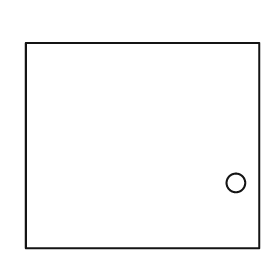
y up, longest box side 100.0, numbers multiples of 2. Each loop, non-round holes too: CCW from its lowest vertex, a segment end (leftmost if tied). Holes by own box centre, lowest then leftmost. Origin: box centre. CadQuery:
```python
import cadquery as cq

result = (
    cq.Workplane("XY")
    .moveTo(-50.0, -44.0)
    .lineTo(50.0, -44.0)
    .lineTo(50.0, 44.0)
    .lineTo(-50.0, 44.0)
    .close()
    .moveTo(40.0, -16.0)
    .circle(4.0)
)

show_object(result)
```